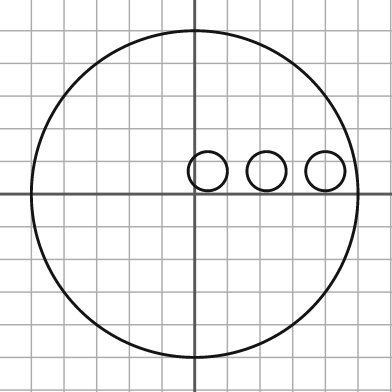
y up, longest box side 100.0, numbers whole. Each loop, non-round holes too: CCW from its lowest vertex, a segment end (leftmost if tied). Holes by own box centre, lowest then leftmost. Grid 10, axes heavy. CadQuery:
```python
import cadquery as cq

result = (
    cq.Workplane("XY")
    .moveTo(0.0, 0.0)
    .circle(50.0)
    .moveTo(4.0, 7.0)
    .circle(6.0)
    .moveTo(22.0, 7.0)
    .circle(6.0)
    .moveTo(40.0, 7.0)
    .circle(6.0)
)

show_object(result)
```